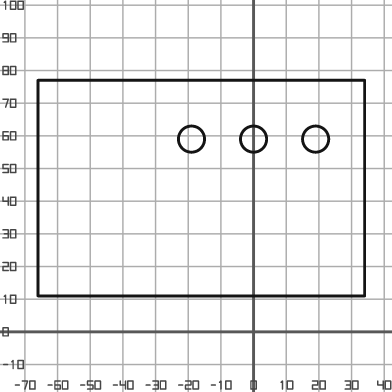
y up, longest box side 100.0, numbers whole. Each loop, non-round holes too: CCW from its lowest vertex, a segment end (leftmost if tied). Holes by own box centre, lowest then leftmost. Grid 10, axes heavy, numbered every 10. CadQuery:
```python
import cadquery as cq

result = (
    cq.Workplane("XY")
    .moveTo(-66.0, 11.0)
    .lineTo(34.0, 11.0)
    .lineTo(34.0, 77.0)
    .lineTo(-66.0, 77.0)
    .close()
    .moveTo(-19.0, 59.0)
    .circle(4.0)
    .moveTo(0.0, 59.0)
    .circle(4.0)
    .moveTo(19.0, 59.0)
    .circle(4.0)
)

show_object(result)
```